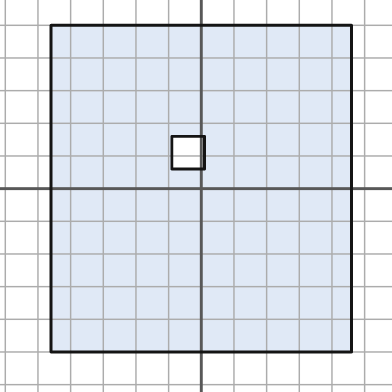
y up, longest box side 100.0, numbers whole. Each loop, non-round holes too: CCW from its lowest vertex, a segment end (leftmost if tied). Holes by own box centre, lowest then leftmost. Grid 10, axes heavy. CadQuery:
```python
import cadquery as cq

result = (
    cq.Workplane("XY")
    .moveTo(-46.0, -50.0)
    .lineTo(46.0, -50.0)
    .lineTo(46.0, 50.0)
    .lineTo(-46.0, 50.0)
    .close()
    .moveTo(-9.0, 6.0)
    .lineTo(1.0, 6.0)
    .lineTo(1.0, 16.0)
    .lineTo(-9.0, 16.0)
    .close()
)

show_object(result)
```